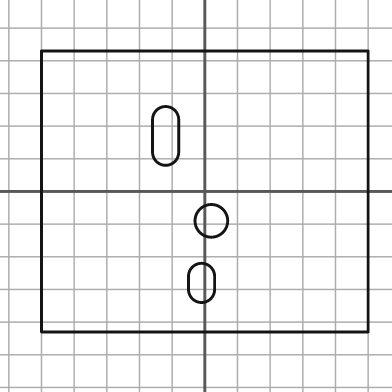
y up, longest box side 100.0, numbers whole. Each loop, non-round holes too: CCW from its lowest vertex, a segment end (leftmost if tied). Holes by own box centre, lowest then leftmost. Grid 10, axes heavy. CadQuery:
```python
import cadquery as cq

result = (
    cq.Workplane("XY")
    .moveTo(-50.0, -43.0)
    .lineTo(50.0, -43.0)
    .lineTo(50.0, 43.0)
    .lineTo(-50.0, 43.0)
    .close()
    .moveTo(-5.0, -30.0)
    .threePointArc((-1.0, -34.0), (3.0, -30.0))
    .lineTo(3.0, -26.0)
    .threePointArc((-1.0, -22.0), (-5.0, -26.0))
    .close()
    .moveTo(2.0, -9.0)
    .circle(5.0)
    .moveTo(-16.0, 12.0)
    .threePointArc((-12.0, 8.0), (-8.0, 12.0))
    .lineTo(-8.0, 22.0)
    .threePointArc((-12.0, 26.0), (-16.0, 22.0))
    .close()
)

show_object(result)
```